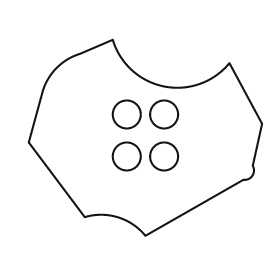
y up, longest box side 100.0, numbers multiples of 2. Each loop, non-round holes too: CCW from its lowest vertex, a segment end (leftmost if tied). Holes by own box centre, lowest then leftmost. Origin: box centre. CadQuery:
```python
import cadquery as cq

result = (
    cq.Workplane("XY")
    .moveTo(0.0, -42.0)
    .lineTo(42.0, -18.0)
    .threePointArc((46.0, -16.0), (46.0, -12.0))
    .lineTo(50.0, 6.0)
    .lineTo(36.0, 32.0)
    .threePointArc((8.0, 22.0), (-14.0, 42.0))
    .lineTo(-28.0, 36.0)
    .threePointArc((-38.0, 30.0), (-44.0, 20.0))
    .lineTo(-50.0, -2.0)
    .lineTo(-26.0, -34.0)
    .threePointArc((-12.0, -34.0), (0.0, -42.0))
    .close()
    .moveTo(-8.0, -8.0)
    .circle(6.0)
    .moveTo(8.0, -8.0)
    .circle(6.0)
    .moveTo(-8.0, 10.0)
    .circle(6.0)
    .moveTo(8.0, 10.0)
    .circle(6.0)
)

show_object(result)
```